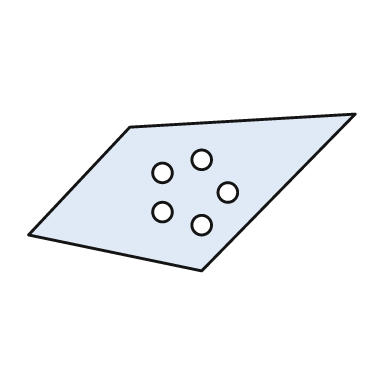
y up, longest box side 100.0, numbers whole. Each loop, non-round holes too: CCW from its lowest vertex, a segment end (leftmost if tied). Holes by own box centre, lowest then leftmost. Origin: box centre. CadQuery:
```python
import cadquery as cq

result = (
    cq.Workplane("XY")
    .moveTo(3.0, -24.0)
    .lineTo(50.0, 24.0)
    .lineTo(-19.0, 20.0)
    .lineTo(-50.0, -13.0)
    .close()
    .moveTo(3.0, -10.0)
    .circle(3.0)
    .moveTo(-9.0, -6.0)
    .circle(3.0)
    .moveTo(11.0, 0.0)
    .circle(3.0)
    .moveTo(-9.0, 6.0)
    .circle(3.0)
    .moveTo(3.0, 10.0)
    .circle(3.0)
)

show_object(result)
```